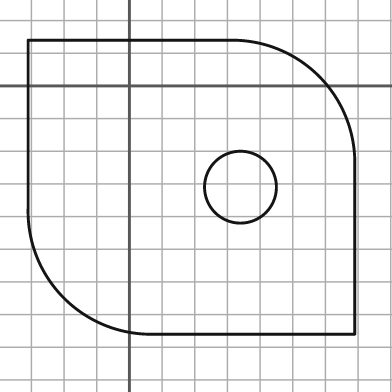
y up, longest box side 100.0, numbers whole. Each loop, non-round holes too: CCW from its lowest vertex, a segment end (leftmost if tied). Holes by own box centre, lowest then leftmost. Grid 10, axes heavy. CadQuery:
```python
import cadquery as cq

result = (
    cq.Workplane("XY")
    .moveTo(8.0, -76.0)
    .lineTo(69.0, -76.0)
    .lineTo(69.0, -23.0)
    .threePointArc((58.0, 3.0), (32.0, 14.0))
    .lineTo(-31.0, 14.0)
    .lineTo(-31.0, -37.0)
    .threePointArc((-20.0, -65.0), (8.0, -76.0))
    .close()
    .moveTo(34.0, -31.0)
    .circle(11.0)
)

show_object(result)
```